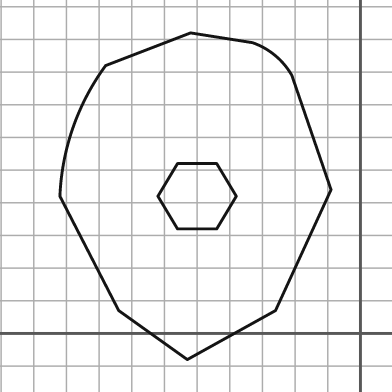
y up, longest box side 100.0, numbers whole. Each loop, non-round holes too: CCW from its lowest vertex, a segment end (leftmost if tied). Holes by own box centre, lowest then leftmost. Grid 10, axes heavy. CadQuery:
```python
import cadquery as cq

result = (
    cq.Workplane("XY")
    .moveTo(-53.0, -8.0)
    .lineTo(-26.0, 7.0)
    .lineTo(-9.0, 44.0)
    .lineTo(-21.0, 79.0)
    .threePointArc((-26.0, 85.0), (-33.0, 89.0))
    .lineTo(-52.0, 92.0)
    .lineTo(-78.0, 82.0)
    .threePointArc((-88.0, 63.0), (-92.0, 42.0))
    .lineTo(-74.0, 7.0)
    .close()
    .moveTo(-56.0, 32.0)
    .lineTo(-44.0, 32.0)
    .lineTo(-38.0, 42.0)
    .lineTo(-44.0, 52.0)
    .lineTo(-56.0, 52.0)
    .lineTo(-62.0, 42.0)
    .close()
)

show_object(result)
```